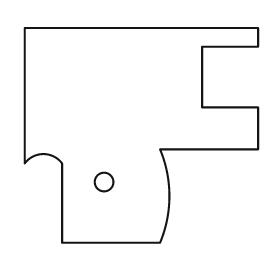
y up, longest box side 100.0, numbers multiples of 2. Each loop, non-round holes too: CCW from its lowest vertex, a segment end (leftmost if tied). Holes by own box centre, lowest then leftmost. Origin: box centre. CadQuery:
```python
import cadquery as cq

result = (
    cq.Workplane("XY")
    .moveTo(-34.0, -46.0)
    .lineTo(8.0, -46.0)
    .threePointArc((12.0, -26.0), (8.0, -6.0))
    .lineTo(50.0, -6.0)
    .lineTo(50.0, 12.0)
    .lineTo(26.0, 12.0)
    .lineTo(26.0, 38.0)
    .lineTo(50.0, 38.0)
    .lineTo(50.0, 46.0)
    .lineTo(-50.0, 46.0)
    .lineTo(-50.0, -12.0)
    .threePointArc((-42.0, -8.0), (-34.0, -12.0))
    .close()
    .moveTo(-16.0, -20.0)
    .circle(4.0)
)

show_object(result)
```